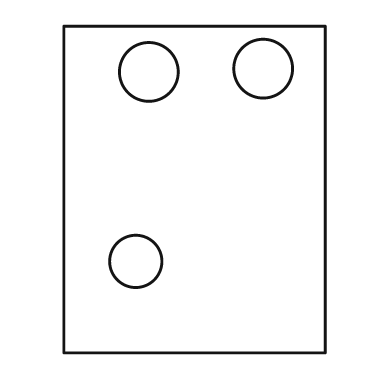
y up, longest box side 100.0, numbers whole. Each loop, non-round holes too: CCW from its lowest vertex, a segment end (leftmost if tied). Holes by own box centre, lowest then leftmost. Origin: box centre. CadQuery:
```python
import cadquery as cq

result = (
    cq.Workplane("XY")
    .moveTo(-40.0, -50.0)
    .lineTo(40.0, -50.0)
    .lineTo(40.0, 50.0)
    .lineTo(-40.0, 50.0)
    .close()
    .moveTo(-18.0, -22.0)
    .circle(8.0)
    .moveTo(-14.0, 36.0)
    .circle(9.0)
    .moveTo(21.0, 37.0)
    .circle(9.0)
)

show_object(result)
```